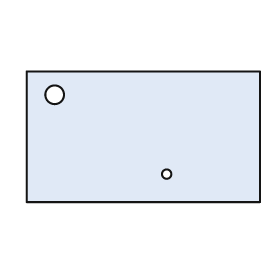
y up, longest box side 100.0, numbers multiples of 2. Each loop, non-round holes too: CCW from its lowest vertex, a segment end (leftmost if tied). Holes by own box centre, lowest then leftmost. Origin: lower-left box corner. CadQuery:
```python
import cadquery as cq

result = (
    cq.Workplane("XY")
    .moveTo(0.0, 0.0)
    .lineTo(100.0, 0.0)
    .lineTo(100.0, 56.0)
    .lineTo(0.0, 56.0)
    .close()
    .moveTo(60.0, 12.0)
    .circle(2.0)
    .moveTo(12.0, 46.0)
    .circle(4.0)
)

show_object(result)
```